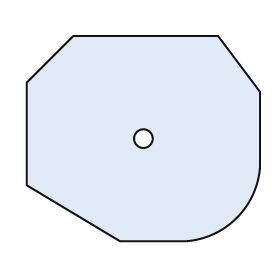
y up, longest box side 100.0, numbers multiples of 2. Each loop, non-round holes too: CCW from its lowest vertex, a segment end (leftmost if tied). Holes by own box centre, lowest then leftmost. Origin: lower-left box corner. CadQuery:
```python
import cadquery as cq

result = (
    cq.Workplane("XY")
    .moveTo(40.0, 0.0)
    .lineTo(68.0, 0.0)
    .threePointArc((90.0, 10.0), (100.0, 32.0))
    .lineTo(100.0, 64.0)
    .lineTo(82.0, 88.0)
    .lineTo(20.0, 88.0)
    .lineTo(0.0, 68.0)
    .lineTo(0.0, 24.0)
    .close()
    .moveTo(50.0, 44.0)
    .circle(4.0)
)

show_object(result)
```